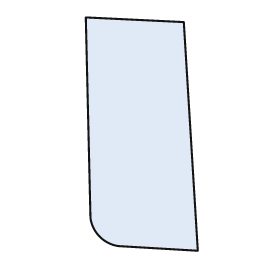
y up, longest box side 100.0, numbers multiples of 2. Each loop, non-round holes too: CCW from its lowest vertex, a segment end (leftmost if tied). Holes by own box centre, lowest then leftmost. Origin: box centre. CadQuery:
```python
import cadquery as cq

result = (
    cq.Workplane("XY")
    .moveTo(24.0, -50.0)
    .lineTo(18.0, 48.0)
    .lineTo(-24.0, 50.0)
    .lineTo(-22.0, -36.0)
    .threePointArc((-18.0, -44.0), (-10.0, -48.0))
    .close()
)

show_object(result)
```